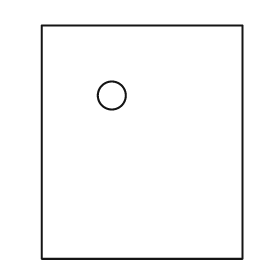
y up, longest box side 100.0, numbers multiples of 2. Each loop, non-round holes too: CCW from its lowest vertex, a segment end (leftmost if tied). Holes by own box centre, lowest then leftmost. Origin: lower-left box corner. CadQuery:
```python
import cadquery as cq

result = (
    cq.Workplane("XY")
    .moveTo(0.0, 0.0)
    .lineTo(86.0, 0.0)
    .lineTo(86.0, 100.0)
    .lineTo(0.0, 100.0)
    .close()
    .moveTo(30.0, 70.0)
    .circle(6.0)
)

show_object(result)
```